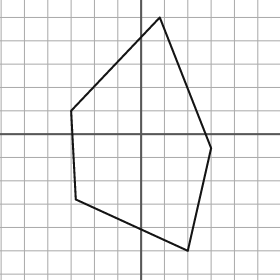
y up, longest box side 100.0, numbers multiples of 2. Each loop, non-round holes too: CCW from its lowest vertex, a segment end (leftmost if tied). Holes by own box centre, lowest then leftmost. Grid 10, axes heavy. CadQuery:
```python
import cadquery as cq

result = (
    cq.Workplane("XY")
    .moveTo(20.0, -50.0)
    .lineTo(30.0, -6.0)
    .lineTo(8.0, 50.0)
    .lineTo(-30.0, 10.0)
    .lineTo(-28.0, -28.0)
    .close()
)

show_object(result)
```